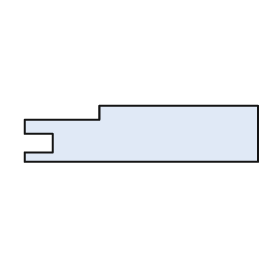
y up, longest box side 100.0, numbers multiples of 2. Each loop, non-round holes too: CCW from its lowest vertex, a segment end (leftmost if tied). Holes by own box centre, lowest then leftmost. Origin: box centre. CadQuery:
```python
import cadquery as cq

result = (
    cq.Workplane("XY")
    .moveTo(-50.0, -12.0)
    .lineTo(50.0, -12.0)
    .lineTo(50.0, 12.0)
    .lineTo(-18.0, 12.0)
    .lineTo(-18.0, 6.0)
    .lineTo(-50.0, 6.0)
    .lineTo(-50.0, 0.0)
    .lineTo(-38.0, 0.0)
    .lineTo(-38.0, -8.0)
    .lineTo(-50.0, -8.0)
    .close()
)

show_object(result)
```